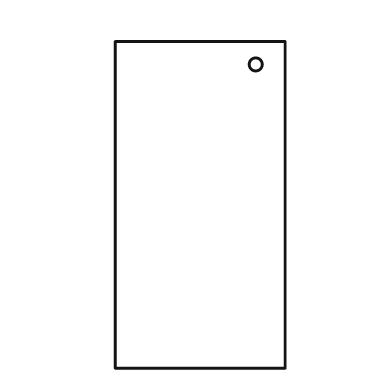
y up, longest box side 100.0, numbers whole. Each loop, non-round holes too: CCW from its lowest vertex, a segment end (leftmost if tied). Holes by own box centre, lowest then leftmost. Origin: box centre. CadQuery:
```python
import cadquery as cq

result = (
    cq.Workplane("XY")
    .moveTo(-26.0, -50.0)
    .lineTo(26.0, -50.0)
    .lineTo(26.0, 50.0)
    .lineTo(-26.0, 50.0)
    .close()
    .moveTo(17.0, 43.0)
    .circle(2.0)
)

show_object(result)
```